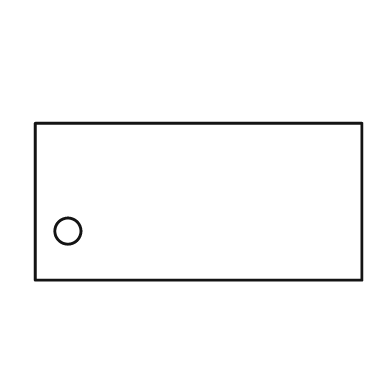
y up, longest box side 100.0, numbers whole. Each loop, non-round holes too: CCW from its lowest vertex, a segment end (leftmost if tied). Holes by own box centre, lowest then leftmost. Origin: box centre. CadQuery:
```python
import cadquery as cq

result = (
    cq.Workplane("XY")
    .moveTo(-50.0, -24.0)
    .lineTo(50.0, -24.0)
    .lineTo(50.0, 24.0)
    .lineTo(-50.0, 24.0)
    .close()
    .moveTo(-40.0, -9.0)
    .circle(4.0)
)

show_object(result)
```